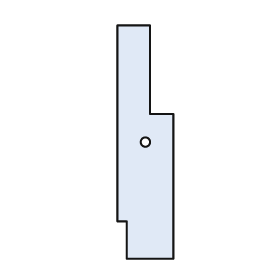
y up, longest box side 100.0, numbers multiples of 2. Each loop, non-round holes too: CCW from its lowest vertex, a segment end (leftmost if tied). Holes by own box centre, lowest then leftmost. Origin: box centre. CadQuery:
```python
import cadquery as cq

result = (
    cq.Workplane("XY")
    .moveTo(-8.0, -50.0)
    .lineTo(12.0, -50.0)
    .lineTo(12.0, 12.0)
    .lineTo(2.0, 12.0)
    .lineTo(2.0, 50.0)
    .lineTo(-12.0, 50.0)
    .lineTo(-12.0, -34.0)
    .lineTo(-8.0, -34.0)
    .close()
    .moveTo(0.0, 0.0)
    .circle(2.0)
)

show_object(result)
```